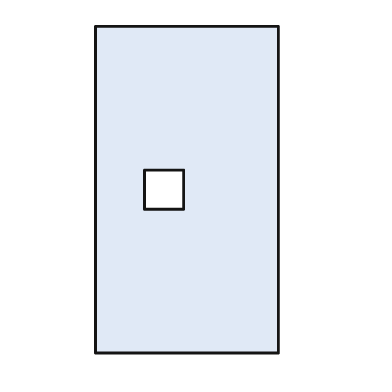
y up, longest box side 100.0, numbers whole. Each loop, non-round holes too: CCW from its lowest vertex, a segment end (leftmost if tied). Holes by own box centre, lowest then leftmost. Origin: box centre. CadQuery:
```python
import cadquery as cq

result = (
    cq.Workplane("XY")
    .moveTo(-28.0, -50.0)
    .lineTo(28.0, -50.0)
    .lineTo(28.0, 50.0)
    .lineTo(-28.0, 50.0)
    .close()
    .moveTo(-13.0, -6.0)
    .lineTo(-1.0, -6.0)
    .lineTo(-1.0, 6.0)
    .lineTo(-13.0, 6.0)
    .close()
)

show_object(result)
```